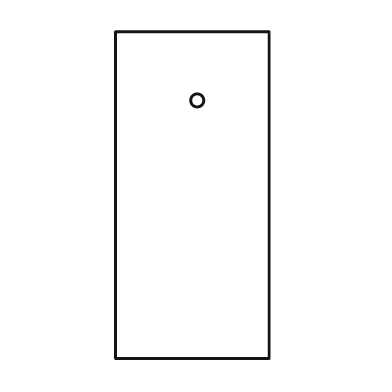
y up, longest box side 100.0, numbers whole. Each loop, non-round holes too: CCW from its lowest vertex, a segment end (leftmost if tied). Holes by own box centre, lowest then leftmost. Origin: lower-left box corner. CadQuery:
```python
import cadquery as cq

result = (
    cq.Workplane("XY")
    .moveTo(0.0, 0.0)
    .lineTo(47.0, 0.0)
    .lineTo(47.0, 100.0)
    .lineTo(0.0, 100.0)
    .close()
    .moveTo(25.0, 79.0)
    .circle(2.0)
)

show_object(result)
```